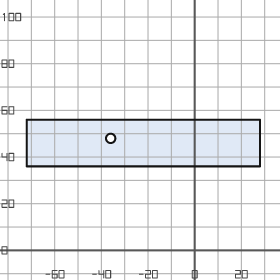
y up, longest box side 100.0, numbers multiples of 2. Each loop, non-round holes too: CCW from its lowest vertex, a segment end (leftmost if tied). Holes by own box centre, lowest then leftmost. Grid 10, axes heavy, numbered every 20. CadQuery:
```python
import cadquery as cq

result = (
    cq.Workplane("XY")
    .moveTo(-72.0, 36.0)
    .lineTo(28.0, 36.0)
    .lineTo(28.0, 56.0)
    .lineTo(-72.0, 56.0)
    .close()
    .moveTo(-36.0, 48.0)
    .circle(2.0)
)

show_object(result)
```